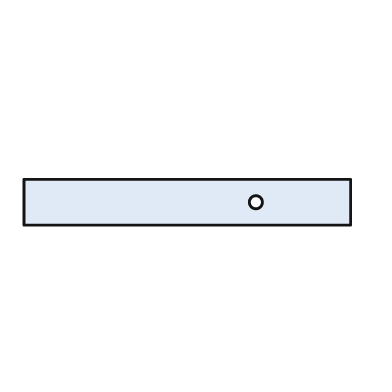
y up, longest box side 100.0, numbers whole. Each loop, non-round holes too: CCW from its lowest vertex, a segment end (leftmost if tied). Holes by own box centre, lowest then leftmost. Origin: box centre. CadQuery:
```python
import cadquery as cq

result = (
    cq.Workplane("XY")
    .moveTo(-50.0, -7.0)
    .lineTo(50.0, -7.0)
    .lineTo(50.0, 7.0)
    .lineTo(-50.0, 7.0)
    .close()
    .moveTo(21.0, 0.0)
    .circle(2.0)
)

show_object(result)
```